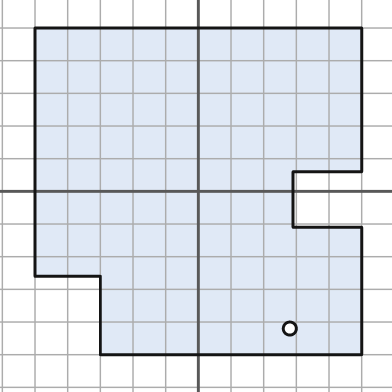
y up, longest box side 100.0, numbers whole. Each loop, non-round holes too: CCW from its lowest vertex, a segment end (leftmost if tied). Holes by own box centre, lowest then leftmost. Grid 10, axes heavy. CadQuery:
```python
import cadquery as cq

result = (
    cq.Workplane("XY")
    .moveTo(-30.0, -50.0)
    .lineTo(50.0, -50.0)
    .lineTo(50.0, -11.0)
    .lineTo(29.0, -11.0)
    .lineTo(29.0, 6.0)
    .lineTo(50.0, 6.0)
    .lineTo(50.0, 50.0)
    .lineTo(-50.0, 50.0)
    .lineTo(-50.0, -26.0)
    .lineTo(-30.0, -26.0)
    .close()
    .moveTo(28.0, -42.0)
    .circle(2.0)
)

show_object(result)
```